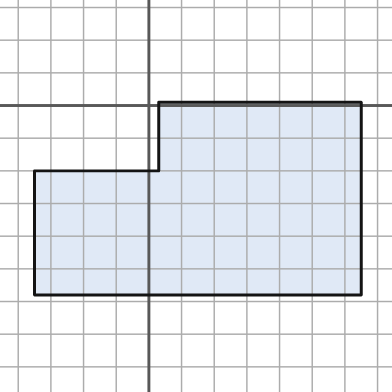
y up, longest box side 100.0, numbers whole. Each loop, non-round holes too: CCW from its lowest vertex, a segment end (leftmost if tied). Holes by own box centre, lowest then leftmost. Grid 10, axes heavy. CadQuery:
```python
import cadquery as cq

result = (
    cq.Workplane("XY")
    .moveTo(-35.0, -58.0)
    .lineTo(65.0, -58.0)
    .lineTo(65.0, 1.0)
    .lineTo(3.0, 1.0)
    .lineTo(3.0, -20.0)
    .lineTo(-35.0, -20.0)
    .close()
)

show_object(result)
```